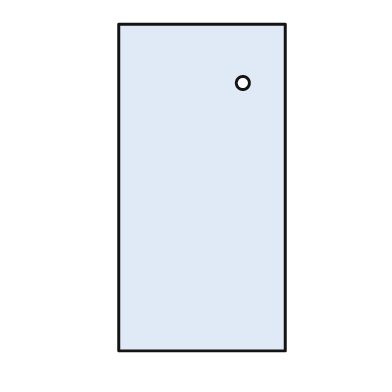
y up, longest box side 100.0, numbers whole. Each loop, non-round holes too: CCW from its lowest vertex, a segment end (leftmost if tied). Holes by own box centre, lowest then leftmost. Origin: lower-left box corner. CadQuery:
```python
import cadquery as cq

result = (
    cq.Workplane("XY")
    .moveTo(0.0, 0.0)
    .lineTo(51.0, 0.0)
    .lineTo(51.0, 100.0)
    .lineTo(0.0, 100.0)
    .close()
    .moveTo(38.0, 82.0)
    .circle(2.0)
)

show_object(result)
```